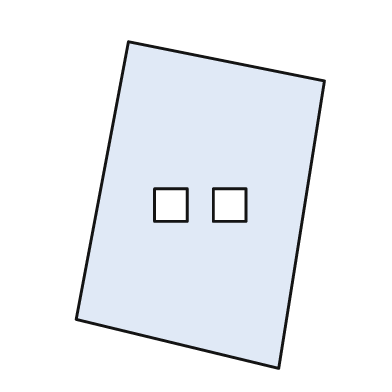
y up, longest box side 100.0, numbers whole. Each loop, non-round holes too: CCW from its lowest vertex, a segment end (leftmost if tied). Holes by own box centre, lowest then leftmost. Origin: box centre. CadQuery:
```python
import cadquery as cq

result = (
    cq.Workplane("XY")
    .moveTo(24.0, -50.0)
    .lineTo(38.0, 38.0)
    .lineTo(-22.0, 50.0)
    .lineTo(-38.0, -35.0)
    .close()
    .moveTo(-14.0, -5.0)
    .lineTo(-4.0, -5.0)
    .lineTo(-4.0, 5.0)
    .lineTo(-14.0, 5.0)
    .close()
    .moveTo(4.0, -5.0)
    .lineTo(14.0, -5.0)
    .lineTo(14.0, 5.0)
    .lineTo(4.0, 5.0)
    .close()
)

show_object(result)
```